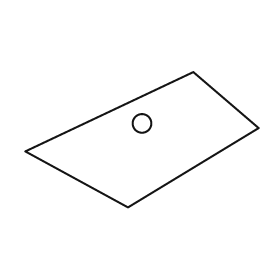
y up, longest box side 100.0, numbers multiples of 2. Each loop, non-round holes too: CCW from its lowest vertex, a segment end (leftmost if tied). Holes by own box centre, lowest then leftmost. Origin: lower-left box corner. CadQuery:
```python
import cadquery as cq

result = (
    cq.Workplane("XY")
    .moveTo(44.0, 0.0)
    .lineTo(100.0, 34.0)
    .lineTo(72.0, 58.0)
    .lineTo(0.0, 24.0)
    .close()
    .moveTo(50.0, 36.0)
    .circle(4.0)
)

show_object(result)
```